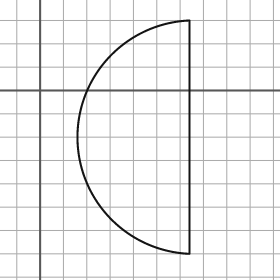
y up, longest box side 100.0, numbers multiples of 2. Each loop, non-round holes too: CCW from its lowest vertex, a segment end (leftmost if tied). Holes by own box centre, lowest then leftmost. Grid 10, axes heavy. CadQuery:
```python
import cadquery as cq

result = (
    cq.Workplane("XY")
    .moveTo(64.0, -70.0)
    .lineTo(64.0, 30.0)
    .threePointArc((16.0, -20.0), (64.0, -70.0))
    .close()
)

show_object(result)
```